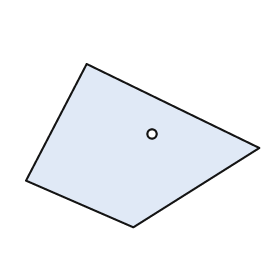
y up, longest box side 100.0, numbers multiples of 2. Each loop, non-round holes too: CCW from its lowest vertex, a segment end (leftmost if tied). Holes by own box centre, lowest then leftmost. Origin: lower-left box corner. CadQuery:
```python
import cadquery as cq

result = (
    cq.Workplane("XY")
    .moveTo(46.0, 0.0)
    .lineTo(100.0, 34.0)
    .lineTo(26.0, 70.0)
    .lineTo(0.0, 20.0)
    .close()
    .moveTo(54.0, 40.0)
    .circle(2.0)
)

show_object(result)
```